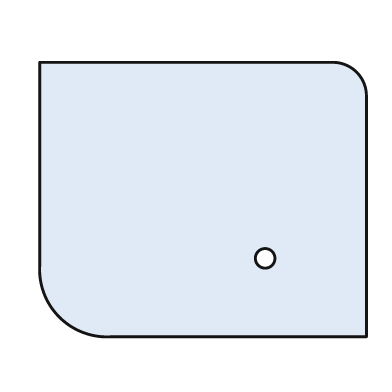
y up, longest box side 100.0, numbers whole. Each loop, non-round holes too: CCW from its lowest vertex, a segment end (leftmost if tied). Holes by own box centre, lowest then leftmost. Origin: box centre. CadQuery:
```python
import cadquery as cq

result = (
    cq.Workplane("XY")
    .moveTo(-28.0, -42.0)
    .lineTo(50.0, -42.0)
    .lineTo(50.0, 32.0)
    .threePointArc((47.0, 39.0), (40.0, 42.0))
    .lineTo(-50.0, 42.0)
    .lineTo(-50.0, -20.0)
    .threePointArc((-44.0, -36.0), (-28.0, -42.0))
    .close()
    .moveTo(19.0, -18.0)
    .circle(3.0)
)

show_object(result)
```